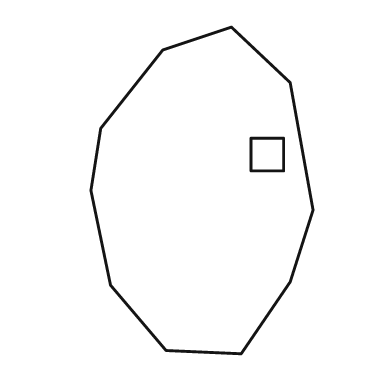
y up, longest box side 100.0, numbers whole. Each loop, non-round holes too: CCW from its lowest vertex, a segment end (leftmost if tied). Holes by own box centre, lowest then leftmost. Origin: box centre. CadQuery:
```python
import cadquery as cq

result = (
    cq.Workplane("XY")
    .moveTo(12.0, -50.0)
    .lineTo(27.0, -28.0)
    .lineTo(34.0, -6.0)
    .lineTo(27.0, 33.0)
    .lineTo(9.0, 50.0)
    .lineTo(-12.0, 43.0)
    .lineTo(-31.0, 19.0)
    .lineTo(-34.0, 0.0)
    .lineTo(-28.0, -29.0)
    .lineTo(-11.0, -49.0)
    .close()
    .moveTo(15.0, 6.0)
    .lineTo(25.0, 6.0)
    .lineTo(25.0, 16.0)
    .lineTo(15.0, 16.0)
    .close()
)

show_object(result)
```